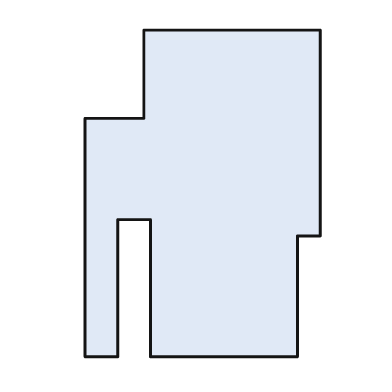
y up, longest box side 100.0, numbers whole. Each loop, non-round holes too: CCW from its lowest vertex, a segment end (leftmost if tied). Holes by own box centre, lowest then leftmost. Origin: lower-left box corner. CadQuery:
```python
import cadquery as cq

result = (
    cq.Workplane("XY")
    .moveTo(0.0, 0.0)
    .lineTo(10.0, 0.0)
    .lineTo(10.0, 42.0)
    .lineTo(20.0, 42.0)
    .lineTo(20.0, 0.0)
    .lineTo(65.0, 0.0)
    .lineTo(65.0, 37.0)
    .lineTo(72.0, 37.0)
    .lineTo(72.0, 100.0)
    .lineTo(18.0, 100.0)
    .lineTo(18.0, 73.0)
    .lineTo(0.0, 73.0)
    .close()
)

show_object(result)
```